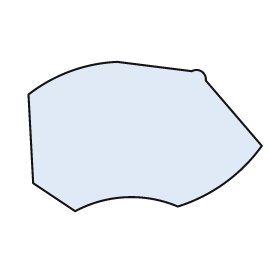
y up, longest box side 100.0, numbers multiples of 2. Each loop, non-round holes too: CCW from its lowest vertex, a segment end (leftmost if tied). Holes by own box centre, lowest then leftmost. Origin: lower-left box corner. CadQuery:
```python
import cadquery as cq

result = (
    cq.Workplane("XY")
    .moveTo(20.0, 0.0)
    .threePointArc((42.0, 6.0), (64.0, 2.0))
    .threePointArc((84.0, 12.0), (100.0, 28.0))
    .lineTo(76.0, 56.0)
    .threePointArc((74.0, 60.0), (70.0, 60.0))
    .lineTo(38.0, 64.0)
    .threePointArc((18.0, 60.0), (0.0, 50.0))
    .lineTo(2.0, 12.0)
    .close()
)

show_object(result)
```